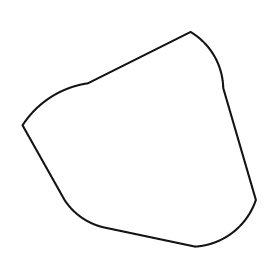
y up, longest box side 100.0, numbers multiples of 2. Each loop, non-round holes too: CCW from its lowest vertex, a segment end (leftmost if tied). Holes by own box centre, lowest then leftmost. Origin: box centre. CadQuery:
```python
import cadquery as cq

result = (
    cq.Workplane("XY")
    .moveTo(24.0, -46.0)
    .threePointArc((40.0, -40.0), (50.0, -26.0))
    .lineTo(36.0, 22.0)
    .threePointArc((32.0, 36.0), (22.0, 46.0))
    .lineTo(-22.0, 24.0)
    .threePointArc((-38.0, 18.0), (-50.0, 6.0))
    .lineTo(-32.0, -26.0)
    .threePointArc((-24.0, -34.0), (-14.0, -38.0))
    .close()
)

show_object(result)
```